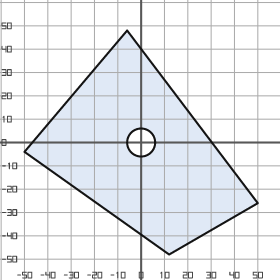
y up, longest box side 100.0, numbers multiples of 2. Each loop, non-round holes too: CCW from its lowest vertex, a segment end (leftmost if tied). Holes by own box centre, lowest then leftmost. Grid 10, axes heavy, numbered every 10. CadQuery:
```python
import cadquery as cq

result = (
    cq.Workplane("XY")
    .moveTo(12.0, -48.0)
    .lineTo(50.0, -26.0)
    .lineTo(-6.0, 48.0)
    .lineTo(-50.0, -4.0)
    .close()
    .moveTo(0.0, 0.0)
    .circle(6.0)
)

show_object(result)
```